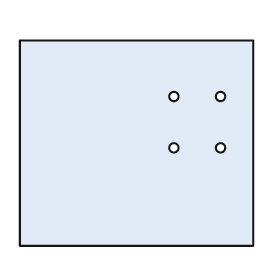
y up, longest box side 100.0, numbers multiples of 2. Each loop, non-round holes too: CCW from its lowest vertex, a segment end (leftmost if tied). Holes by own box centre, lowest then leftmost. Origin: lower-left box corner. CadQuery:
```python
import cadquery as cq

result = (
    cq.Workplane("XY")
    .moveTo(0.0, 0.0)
    .lineTo(100.0, 0.0)
    .lineTo(100.0, 88.0)
    .lineTo(0.0, 88.0)
    .close()
    .moveTo(66.0, 42.0)
    .circle(2.0)
    .moveTo(86.0, 42.0)
    .circle(2.0)
    .moveTo(66.0, 64.0)
    .circle(2.0)
    .moveTo(86.0, 64.0)
    .circle(2.0)
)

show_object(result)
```